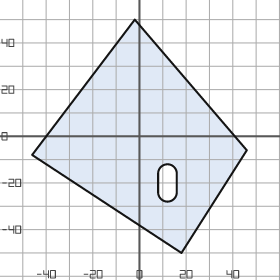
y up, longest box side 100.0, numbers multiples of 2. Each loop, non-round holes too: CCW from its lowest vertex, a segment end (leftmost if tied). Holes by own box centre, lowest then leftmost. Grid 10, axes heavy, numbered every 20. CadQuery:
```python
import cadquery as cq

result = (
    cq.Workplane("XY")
    .moveTo(18.0, -50.0)
    .lineTo(46.0, -6.0)
    .lineTo(-2.0, 50.0)
    .lineTo(-46.0, -8.0)
    .close()
    .moveTo(8.0, -24.0)
    .threePointArc((12.0, -28.0), (16.0, -24.0))
    .lineTo(16.0, -16.0)
    .threePointArc((12.0, -12.0), (8.0, -16.0))
    .close()
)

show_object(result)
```